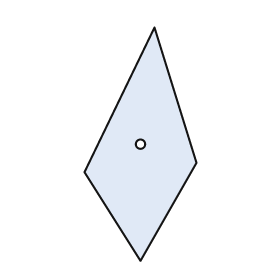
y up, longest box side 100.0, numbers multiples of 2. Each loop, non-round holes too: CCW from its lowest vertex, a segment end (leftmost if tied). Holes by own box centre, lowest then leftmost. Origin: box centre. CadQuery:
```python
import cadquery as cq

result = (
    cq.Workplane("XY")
    .moveTo(0.0, -50.0)
    .lineTo(24.0, -8.0)
    .lineTo(6.0, 50.0)
    .lineTo(-24.0, -12.0)
    .close()
    .moveTo(0.0, 0.0)
    .circle(2.0)
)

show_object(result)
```